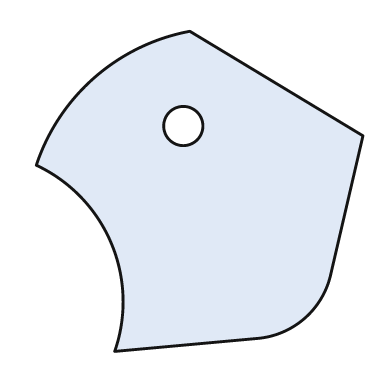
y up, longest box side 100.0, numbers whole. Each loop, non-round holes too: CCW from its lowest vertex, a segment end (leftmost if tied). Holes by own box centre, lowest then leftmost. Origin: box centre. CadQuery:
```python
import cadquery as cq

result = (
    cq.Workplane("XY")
    .moveTo(-26.0, -49.0)
    .lineTo(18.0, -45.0)
    .threePointArc((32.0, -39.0), (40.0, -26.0))
    .lineTo(50.0, 17.0)
    .lineTo(-3.0, 49.0)
    .threePointArc((-32.0, 35.0), (-50.0, 8.0))
    .threePointArc((-27.0, -16.0), (-26.0, -49.0))
    .close()
    .moveTo(-5.0, 20.0)
    .circle(6.0)
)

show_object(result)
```